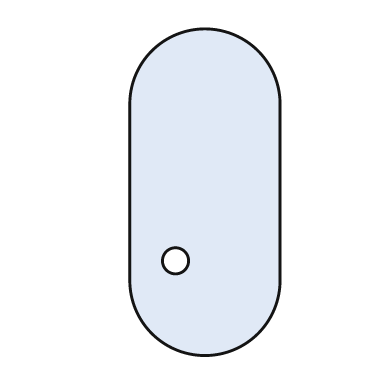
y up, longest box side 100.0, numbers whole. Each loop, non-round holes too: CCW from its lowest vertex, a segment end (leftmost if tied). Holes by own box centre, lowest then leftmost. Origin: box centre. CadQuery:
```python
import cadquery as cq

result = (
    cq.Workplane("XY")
    .moveTo(-23.0, -27.0)
    .threePointArc((0.0, -50.0), (23.0, -27.0))
    .lineTo(23.0, 27.0)
    .threePointArc((0.0, 50.0), (-23.0, 27.0))
    .close()
    .moveTo(-9.0, -21.0)
    .circle(4.0)
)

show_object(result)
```